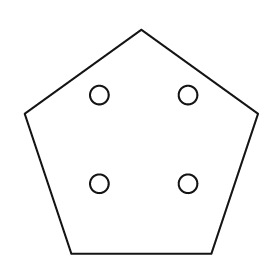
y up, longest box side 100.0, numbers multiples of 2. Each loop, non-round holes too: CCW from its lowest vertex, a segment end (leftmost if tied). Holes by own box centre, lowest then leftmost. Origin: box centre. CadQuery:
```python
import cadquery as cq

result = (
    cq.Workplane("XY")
    .moveTo(-30.0, -48.0)
    .lineTo(30.0, -48.0)
    .lineTo(50.0, 12.0)
    .lineTo(0.0, 48.0)
    .lineTo(-50.0, 12.0)
    .close()
    .moveTo(-18.0, -18.0)
    .circle(4.0)
    .moveTo(20.0, -18.0)
    .circle(4.0)
    .moveTo(-18.0, 20.0)
    .circle(4.0)
    .moveTo(20.0, 20.0)
    .circle(4.0)
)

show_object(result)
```